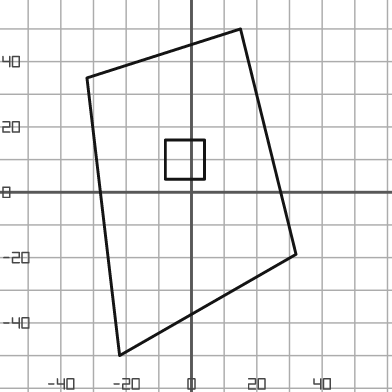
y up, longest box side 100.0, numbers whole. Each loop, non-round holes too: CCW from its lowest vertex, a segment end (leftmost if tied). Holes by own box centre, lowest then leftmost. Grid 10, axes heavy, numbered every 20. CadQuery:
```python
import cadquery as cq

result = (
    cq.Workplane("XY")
    .moveTo(-22.0, -50.0)
    .lineTo(32.0, -19.0)
    .lineTo(15.0, 50.0)
    .lineTo(-32.0, 35.0)
    .close()
    .moveTo(-8.0, 4.0)
    .lineTo(4.0, 4.0)
    .lineTo(4.0, 16.0)
    .lineTo(-8.0, 16.0)
    .close()
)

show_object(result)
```